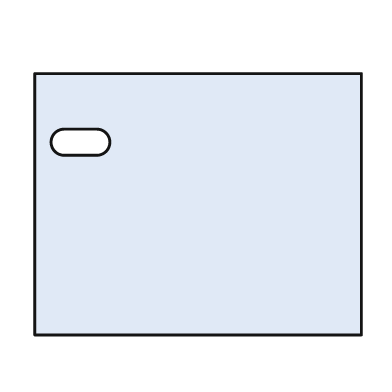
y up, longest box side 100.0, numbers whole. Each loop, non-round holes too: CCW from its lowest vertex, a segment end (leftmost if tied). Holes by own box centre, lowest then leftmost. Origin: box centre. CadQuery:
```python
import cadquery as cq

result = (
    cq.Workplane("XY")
    .moveTo(-50.0, -40.0)
    .lineTo(50.0, -40.0)
    .lineTo(50.0, 40.0)
    .lineTo(-50.0, 40.0)
    .close()
    .moveTo(-41.0, 15.0)
    .lineTo(-31.0, 15.0)
    .threePointArc((-27.0, 19.0), (-31.0, 23.0))
    .lineTo(-41.0, 23.0)
    .threePointArc((-45.0, 19.0), (-41.0, 15.0))
    .close()
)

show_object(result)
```